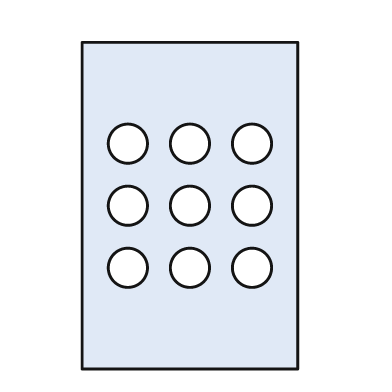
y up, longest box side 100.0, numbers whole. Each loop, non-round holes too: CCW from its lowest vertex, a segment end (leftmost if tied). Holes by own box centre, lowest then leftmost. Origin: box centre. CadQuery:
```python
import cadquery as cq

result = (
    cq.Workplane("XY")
    .moveTo(-33.0, -50.0)
    .lineTo(33.0, -50.0)
    .lineTo(33.0, 50.0)
    .lineTo(-33.0, 50.0)
    .close()
    .moveTo(-19.0, -19.0)
    .circle(6.0)
    .moveTo(0.0, -19.0)
    .circle(6.0)
    .moveTo(19.0, -19.0)
    .circle(6.0)
    .moveTo(-19.0, 0.0)
    .circle(6.0)
    .moveTo(0.0, 0.0)
    .circle(6.0)
    .moveTo(19.0, 0.0)
    .circle(6.0)
    .moveTo(-19.0, 19.0)
    .circle(6.0)
    .moveTo(0.0, 19.0)
    .circle(6.0)
    .moveTo(19.0, 19.0)
    .circle(6.0)
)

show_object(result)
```